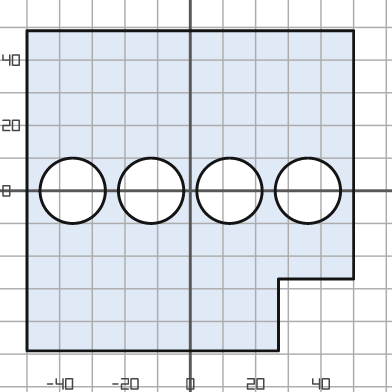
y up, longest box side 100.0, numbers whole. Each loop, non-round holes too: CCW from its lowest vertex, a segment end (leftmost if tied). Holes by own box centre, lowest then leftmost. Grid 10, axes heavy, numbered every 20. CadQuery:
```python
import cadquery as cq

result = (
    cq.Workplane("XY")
    .moveTo(-50.0, -49.0)
    .lineTo(27.0, -49.0)
    .lineTo(27.0, -27.0)
    .lineTo(50.0, -27.0)
    .lineTo(50.0, 49.0)
    .lineTo(-50.0, 49.0)
    .close()
    .moveTo(-36.0, 0.0)
    .circle(10.0)
    .moveTo(-12.0, 0.0)
    .circle(10.0)
    .moveTo(12.0, 0.0)
    .circle(10.0)
    .moveTo(36.0, 0.0)
    .circle(10.0)
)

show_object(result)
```